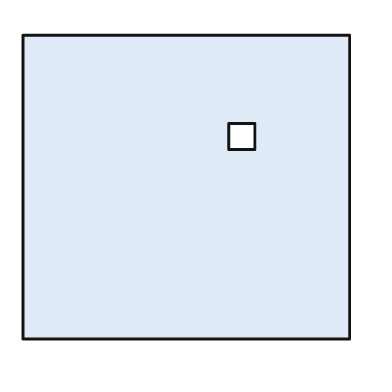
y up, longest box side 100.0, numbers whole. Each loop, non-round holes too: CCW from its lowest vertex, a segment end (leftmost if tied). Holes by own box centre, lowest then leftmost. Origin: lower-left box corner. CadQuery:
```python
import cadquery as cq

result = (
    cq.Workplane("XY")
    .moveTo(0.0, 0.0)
    .lineTo(100.0, 0.0)
    .lineTo(100.0, 93.0)
    .lineTo(0.0, 93.0)
    .close()
    .moveTo(63.0, 58.0)
    .lineTo(71.0, 58.0)
    .lineTo(71.0, 66.0)
    .lineTo(63.0, 66.0)
    .close()
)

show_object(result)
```